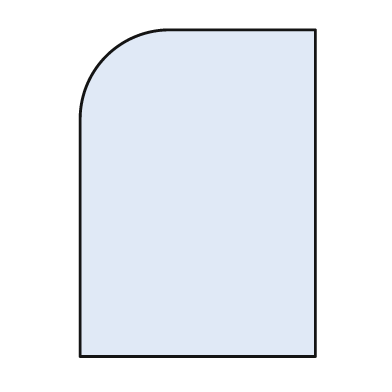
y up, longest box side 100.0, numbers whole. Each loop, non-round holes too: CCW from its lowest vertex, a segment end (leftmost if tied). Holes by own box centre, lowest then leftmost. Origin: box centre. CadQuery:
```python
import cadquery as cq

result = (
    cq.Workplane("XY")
    .moveTo(-36.0, -50.0)
    .lineTo(36.0, -50.0)
    .lineTo(36.0, 50.0)
    .lineTo(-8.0, 50.0)
    .threePointArc((-28.0, 42.0), (-36.0, 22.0))
    .close()
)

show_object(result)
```